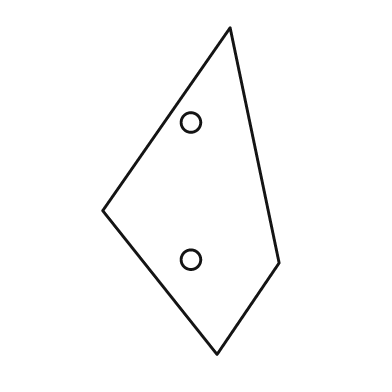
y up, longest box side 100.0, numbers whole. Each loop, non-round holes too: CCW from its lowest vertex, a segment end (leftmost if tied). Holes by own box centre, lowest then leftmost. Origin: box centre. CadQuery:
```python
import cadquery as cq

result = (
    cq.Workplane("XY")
    .moveTo(8.0, -50.0)
    .lineTo(27.0, -22.0)
    .lineTo(12.0, 50.0)
    .lineTo(-27.0, -6.0)
    .close()
    .moveTo(0.0, -21.0)
    .circle(3.0)
    .moveTo(0.0, 21.0)
    .circle(3.0)
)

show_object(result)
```